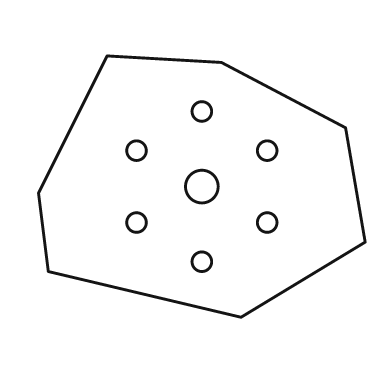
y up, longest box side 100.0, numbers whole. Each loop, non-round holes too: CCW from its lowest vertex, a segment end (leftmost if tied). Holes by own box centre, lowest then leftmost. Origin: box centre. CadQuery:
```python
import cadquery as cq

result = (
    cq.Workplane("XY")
    .moveTo(12.0, -40.0)
    .lineTo(50.0, -17.0)
    .lineTo(44.0, 18.0)
    .lineTo(6.0, 38.0)
    .lineTo(-29.0, 40.0)
    .lineTo(-50.0, -2.0)
    .lineTo(-47.0, -26.0)
    .close()
    .moveTo(0.0, -23.0)
    .circle(3.0)
    .moveTo(-20.0, -11.0)
    .circle(3.0)
    .moveTo(20.0, -11.0)
    .circle(3.0)
    .moveTo(0.0, 0.0)
    .circle(5.0)
    .moveTo(-20.0, 11.0)
    .circle(3.0)
    .moveTo(20.0, 11.0)
    .circle(3.0)
    .moveTo(0.0, 23.0)
    .circle(3.0)
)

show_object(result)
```